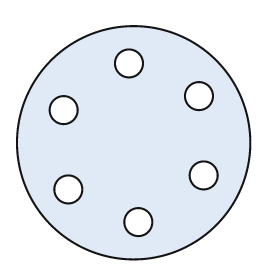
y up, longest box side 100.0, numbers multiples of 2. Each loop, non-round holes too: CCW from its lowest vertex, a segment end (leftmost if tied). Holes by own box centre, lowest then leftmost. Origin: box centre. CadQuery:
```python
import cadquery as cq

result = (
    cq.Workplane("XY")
    .moveTo(0.0, 0.0)
    .circle(50.0)
    .moveTo(2.0, -34.0)
    .circle(6.0)
    .moveTo(-28.0, -20.0)
    .circle(6.0)
    .moveTo(30.0, -14.0)
    .circle(6.0)
    .moveTo(-30.0, 14.0)
    .circle(6.0)
    .moveTo(28.0, 20.0)
    .circle(6.0)
    .moveTo(-2.0, 34.0)
    .circle(6.0)
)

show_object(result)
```